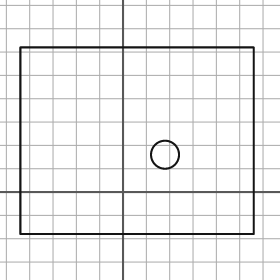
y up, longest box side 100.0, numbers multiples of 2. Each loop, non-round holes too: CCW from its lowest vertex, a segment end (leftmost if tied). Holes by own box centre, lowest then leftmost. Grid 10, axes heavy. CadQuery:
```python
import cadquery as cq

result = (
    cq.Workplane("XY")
    .moveTo(-44.0, -18.0)
    .lineTo(56.0, -18.0)
    .lineTo(56.0, 62.0)
    .lineTo(-44.0, 62.0)
    .close()
    .moveTo(18.0, 16.0)
    .circle(6.0)
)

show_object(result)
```